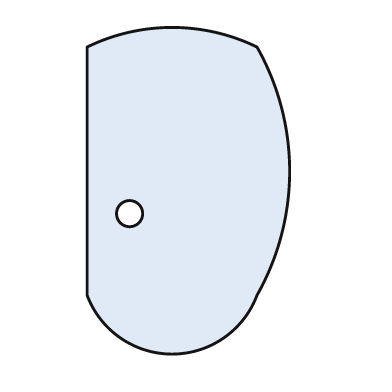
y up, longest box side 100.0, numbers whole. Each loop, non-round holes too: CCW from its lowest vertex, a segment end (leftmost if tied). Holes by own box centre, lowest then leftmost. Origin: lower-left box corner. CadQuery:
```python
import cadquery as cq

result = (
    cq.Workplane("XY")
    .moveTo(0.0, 18.0)
    .threePointArc((26.0, 0.0), (52.0, 18.0))
    .threePointArc((62.0, 56.0), (52.0, 94.0))
    .threePointArc((26.0, 100.0), (0.0, 94.0))
    .close()
    .moveTo(13.0, 43.0)
    .circle(4.0)
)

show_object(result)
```